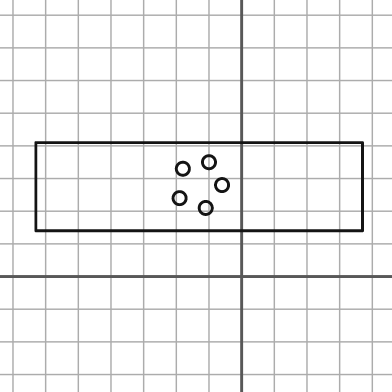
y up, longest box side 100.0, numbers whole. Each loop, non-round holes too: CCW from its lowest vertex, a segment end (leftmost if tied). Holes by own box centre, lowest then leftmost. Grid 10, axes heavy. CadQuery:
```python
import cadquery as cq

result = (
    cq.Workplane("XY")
    .moveTo(-63.0, 14.0)
    .lineTo(37.0, 14.0)
    .lineTo(37.0, 41.0)
    .lineTo(-63.0, 41.0)
    .close()
    .moveTo(-11.0, 21.0)
    .circle(2.0)
    .moveTo(-19.0, 24.0)
    .circle(2.0)
    .moveTo(-6.0, 28.0)
    .circle(2.0)
    .moveTo(-18.0, 33.0)
    .circle(2.0)
    .moveTo(-10.0, 35.0)
    .circle(2.0)
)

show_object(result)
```